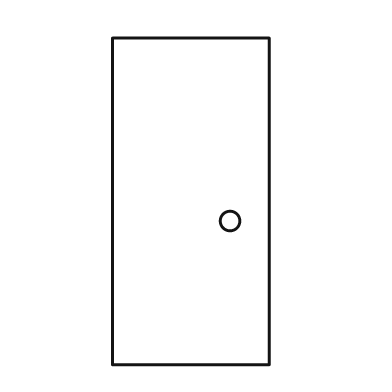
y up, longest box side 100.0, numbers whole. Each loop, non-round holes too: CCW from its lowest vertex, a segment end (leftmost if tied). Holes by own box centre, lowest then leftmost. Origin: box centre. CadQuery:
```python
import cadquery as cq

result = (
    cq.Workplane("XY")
    .moveTo(-24.0, -50.0)
    .lineTo(24.0, -50.0)
    .lineTo(24.0, 50.0)
    .lineTo(-24.0, 50.0)
    .close()
    .moveTo(12.0, -6.0)
    .circle(3.0)
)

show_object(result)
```